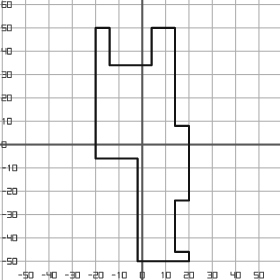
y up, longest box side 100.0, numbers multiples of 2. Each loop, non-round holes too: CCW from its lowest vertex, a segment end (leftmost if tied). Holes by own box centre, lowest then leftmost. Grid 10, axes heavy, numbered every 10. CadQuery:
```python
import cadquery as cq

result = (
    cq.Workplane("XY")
    .moveTo(-2.0, -50.0)
    .lineTo(20.0, -50.0)
    .lineTo(20.0, -46.0)
    .lineTo(14.0, -46.0)
    .lineTo(14.0, -24.0)
    .lineTo(20.0, -24.0)
    .lineTo(20.0, 8.0)
    .lineTo(14.0, 8.0)
    .lineTo(14.0, 50.0)
    .lineTo(4.0, 50.0)
    .lineTo(4.0, 34.0)
    .lineTo(-14.0, 34.0)
    .lineTo(-14.0, 50.0)
    .lineTo(-20.0, 50.0)
    .lineTo(-20.0, -6.0)
    .lineTo(-2.0, -6.0)
    .close()
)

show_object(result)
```